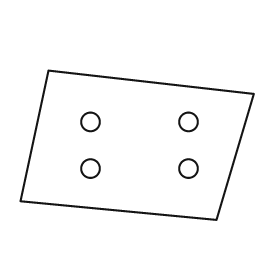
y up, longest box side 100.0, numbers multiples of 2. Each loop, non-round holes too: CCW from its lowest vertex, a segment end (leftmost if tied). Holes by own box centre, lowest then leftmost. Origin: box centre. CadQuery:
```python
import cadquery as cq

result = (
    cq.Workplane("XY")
    .moveTo(34.0, -32.0)
    .lineTo(50.0, 22.0)
    .lineTo(-38.0, 32.0)
    .lineTo(-50.0, -24.0)
    .close()
    .moveTo(-20.0, -10.0)
    .circle(4.0)
    .moveTo(22.0, -10.0)
    .circle(4.0)
    .moveTo(-20.0, 10.0)
    .circle(4.0)
    .moveTo(22.0, 10.0)
    .circle(4.0)
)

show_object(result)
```